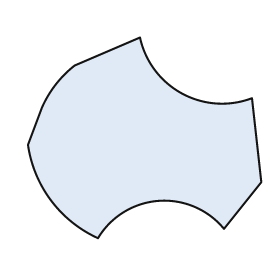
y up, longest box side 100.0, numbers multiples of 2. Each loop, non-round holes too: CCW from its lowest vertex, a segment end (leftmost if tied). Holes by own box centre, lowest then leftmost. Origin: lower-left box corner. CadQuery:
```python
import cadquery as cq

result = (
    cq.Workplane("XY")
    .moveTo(30.0, 0.0)
    .threePointArc((56.0, 16.0), (84.0, 4.0))
    .lineTo(100.0, 24.0)
    .lineTo(96.0, 60.0)
    .threePointArc((66.0, 62.0), (48.0, 86.0))
    .lineTo(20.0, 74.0)
    .threePointArc((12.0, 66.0), (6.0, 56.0))
    .lineTo(0.0, 40.0)
    .threePointArc((10.0, 16.0), (30.0, 0.0))
    .close()
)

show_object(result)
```